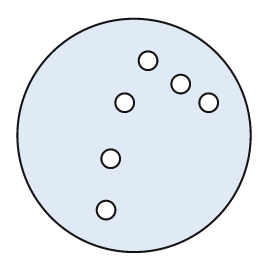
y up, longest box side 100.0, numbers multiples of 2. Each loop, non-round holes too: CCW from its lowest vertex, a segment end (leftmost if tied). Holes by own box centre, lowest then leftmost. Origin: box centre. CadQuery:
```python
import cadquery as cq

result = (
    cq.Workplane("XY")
    .moveTo(0.0, 0.0)
    .circle(50.0)
    .moveTo(-12.0, -32.0)
    .circle(4.0)
    .moveTo(-10.0, -10.0)
    .circle(4.0)
    .moveTo(-4.0, 14.0)
    .circle(4.0)
    .moveTo(32.0, 14.0)
    .circle(4.0)
    .moveTo(20.0, 22.0)
    .circle(4.0)
    .moveTo(6.0, 32.0)
    .circle(4.0)
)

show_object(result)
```